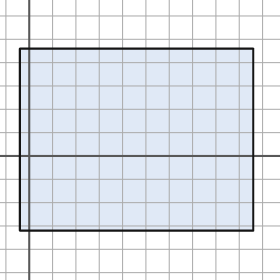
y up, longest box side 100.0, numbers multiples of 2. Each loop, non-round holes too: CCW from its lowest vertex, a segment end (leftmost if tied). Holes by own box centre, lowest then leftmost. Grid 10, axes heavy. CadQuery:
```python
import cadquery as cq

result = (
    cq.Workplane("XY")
    .moveTo(-4.0, -32.0)
    .lineTo(96.0, -32.0)
    .lineTo(96.0, 46.0)
    .lineTo(-4.0, 46.0)
    .close()
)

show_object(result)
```